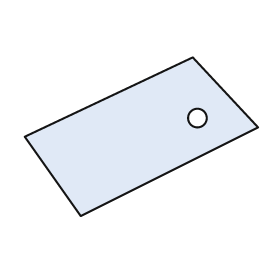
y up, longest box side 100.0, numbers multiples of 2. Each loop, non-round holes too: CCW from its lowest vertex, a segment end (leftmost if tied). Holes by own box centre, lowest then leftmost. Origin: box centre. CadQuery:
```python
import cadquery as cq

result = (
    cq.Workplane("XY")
    .moveTo(-26.0, -34.0)
    .lineTo(50.0, 4.0)
    .lineTo(22.0, 34.0)
    .lineTo(-50.0, 0.0)
    .close()
    .moveTo(24.0, 8.0)
    .circle(4.0)
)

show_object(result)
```